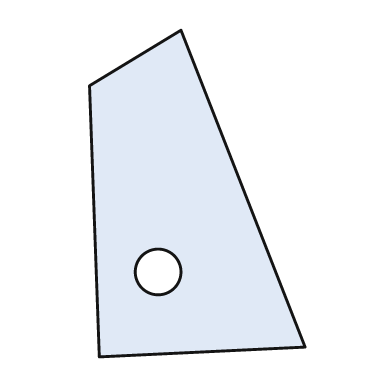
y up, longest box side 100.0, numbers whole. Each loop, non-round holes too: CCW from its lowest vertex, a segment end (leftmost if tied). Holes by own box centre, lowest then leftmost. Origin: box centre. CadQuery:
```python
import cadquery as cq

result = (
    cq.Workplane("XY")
    .moveTo(-30.0, -50.0)
    .lineTo(33.0, -47.0)
    .lineTo(-5.0, 50.0)
    .lineTo(-33.0, 33.0)
    .close()
    .moveTo(-12.0, -24.0)
    .circle(7.0)
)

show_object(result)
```